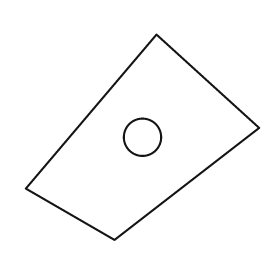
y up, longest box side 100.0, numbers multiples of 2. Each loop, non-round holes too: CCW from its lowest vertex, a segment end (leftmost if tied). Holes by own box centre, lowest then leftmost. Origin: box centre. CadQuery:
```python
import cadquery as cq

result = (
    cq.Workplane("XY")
    .moveTo(-12.0, -44.0)
    .lineTo(50.0, 4.0)
    .lineTo(6.0, 44.0)
    .lineTo(-50.0, -22.0)
    .close()
    .moveTo(0.0, 0.0)
    .circle(8.0)
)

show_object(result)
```